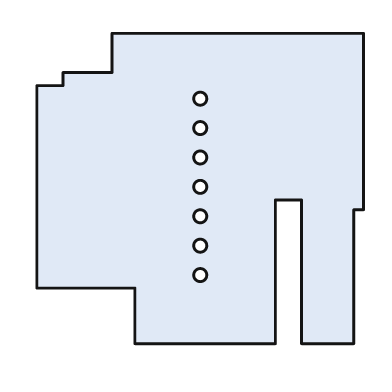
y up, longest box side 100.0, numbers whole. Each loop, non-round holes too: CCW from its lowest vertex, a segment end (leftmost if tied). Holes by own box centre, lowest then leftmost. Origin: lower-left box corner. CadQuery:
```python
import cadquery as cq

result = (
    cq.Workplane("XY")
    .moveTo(30.0, 0.0)
    .lineTo(73.0, 0.0)
    .lineTo(73.0, 44.0)
    .lineTo(81.0, 44.0)
    .lineTo(81.0, 0.0)
    .lineTo(97.0, 0.0)
    .lineTo(97.0, 41.0)
    .lineTo(100.0, 41.0)
    .lineTo(100.0, 95.0)
    .lineTo(23.0, 95.0)
    .lineTo(23.0, 83.0)
    .lineTo(8.0, 83.0)
    .lineTo(8.0, 79.0)
    .lineTo(0.0, 79.0)
    .lineTo(0.0, 17.0)
    .lineTo(30.0, 17.0)
    .close()
    .moveTo(50.0, 21.0)
    .circle(2.0)
    .moveTo(50.0, 30.0)
    .circle(2.0)
    .moveTo(50.0, 39.0)
    .circle(2.0)
    .moveTo(50.0, 48.0)
    .circle(2.0)
    .moveTo(50.0, 57.0)
    .circle(2.0)
    .moveTo(50.0, 66.0)
    .circle(2.0)
    .moveTo(50.0, 75.0)
    .circle(2.0)
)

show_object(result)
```